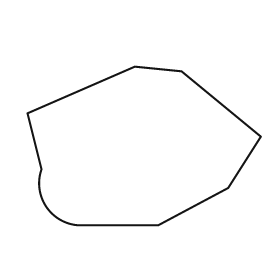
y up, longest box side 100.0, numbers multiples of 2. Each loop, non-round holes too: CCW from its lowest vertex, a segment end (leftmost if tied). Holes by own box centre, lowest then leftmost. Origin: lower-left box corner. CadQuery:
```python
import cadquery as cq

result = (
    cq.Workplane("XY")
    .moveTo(22.0, 0.0)
    .lineTo(56.0, 0.0)
    .lineTo(86.0, 16.0)
    .lineTo(100.0, 38.0)
    .lineTo(66.0, 66.0)
    .lineTo(46.0, 68.0)
    .lineTo(0.0, 48.0)
    .lineTo(6.0, 24.0)
    .threePointArc((8.0, 8.0), (22.0, 0.0))
    .close()
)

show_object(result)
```